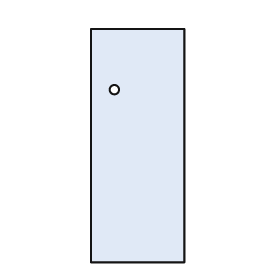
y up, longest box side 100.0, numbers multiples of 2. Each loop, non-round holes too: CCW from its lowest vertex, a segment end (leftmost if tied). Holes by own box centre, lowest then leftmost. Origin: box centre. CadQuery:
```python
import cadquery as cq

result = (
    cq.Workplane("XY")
    .moveTo(-20.0, -50.0)
    .lineTo(20.0, -50.0)
    .lineTo(20.0, 50.0)
    .lineTo(-20.0, 50.0)
    .close()
    .moveTo(-10.0, 24.0)
    .circle(2.0)
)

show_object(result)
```